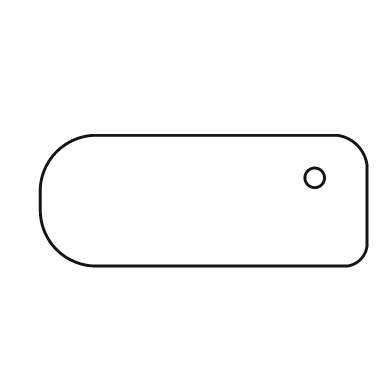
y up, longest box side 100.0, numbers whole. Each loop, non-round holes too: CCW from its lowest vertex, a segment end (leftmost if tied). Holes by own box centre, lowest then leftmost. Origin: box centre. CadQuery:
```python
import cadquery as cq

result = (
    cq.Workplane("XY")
    .moveTo(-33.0, -20.0)
    .lineTo(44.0, -20.0)
    .threePointArc((48.0, -18.0), (50.0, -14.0))
    .lineTo(50.0, 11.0)
    .threePointArc((47.0, 17.0), (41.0, 20.0))
    .lineTo(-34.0, 20.0)
    .threePointArc((-45.0, 15.0), (-50.0, 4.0))
    .lineTo(-50.0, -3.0)
    .threePointArc((-45.0, -15.0), (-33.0, -20.0))
    .close()
    .moveTo(34.0, 7.0)
    .circle(3.0)
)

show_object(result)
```